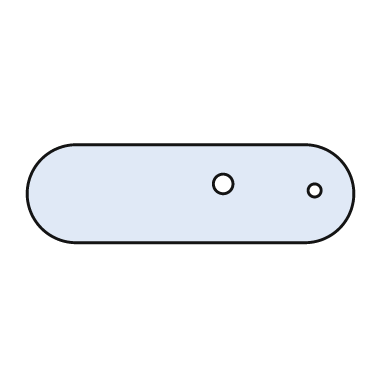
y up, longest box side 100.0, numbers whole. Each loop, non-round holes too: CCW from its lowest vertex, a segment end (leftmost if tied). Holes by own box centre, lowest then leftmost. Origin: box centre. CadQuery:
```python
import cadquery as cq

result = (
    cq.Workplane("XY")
    .moveTo(-35.0, -15.0)
    .lineTo(35.0, -15.0)
    .threePointArc((50.0, 0.0), (35.0, 15.0))
    .lineTo(-35.0, 15.0)
    .threePointArc((-50.0, 0.0), (-35.0, -15.0))
    .close()
    .moveTo(38.0, 1.0)
    .circle(2.0)
    .moveTo(10.0, 3.0)
    .circle(3.0)
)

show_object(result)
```